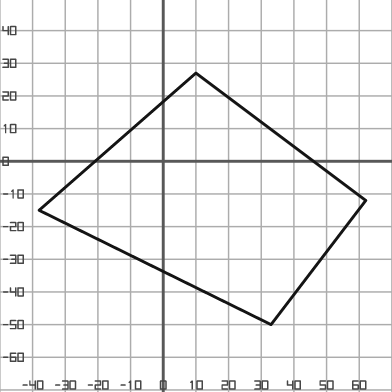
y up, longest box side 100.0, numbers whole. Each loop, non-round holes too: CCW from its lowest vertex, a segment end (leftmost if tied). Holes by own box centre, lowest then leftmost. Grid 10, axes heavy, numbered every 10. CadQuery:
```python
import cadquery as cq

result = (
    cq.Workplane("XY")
    .moveTo(33.0, -50.0)
    .lineTo(62.0, -12.0)
    .lineTo(10.0, 27.0)
    .lineTo(-38.0, -15.0)
    .close()
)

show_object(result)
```